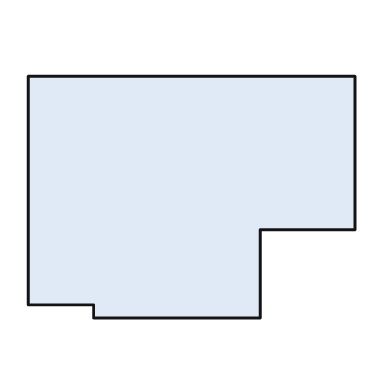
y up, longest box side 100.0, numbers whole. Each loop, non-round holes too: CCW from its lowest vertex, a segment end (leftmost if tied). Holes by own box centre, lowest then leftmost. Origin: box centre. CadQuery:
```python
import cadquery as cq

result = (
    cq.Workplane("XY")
    .moveTo(-30.0, -37.0)
    .lineTo(21.0, -37.0)
    .lineTo(21.0, -10.0)
    .lineTo(50.0, -10.0)
    .lineTo(50.0, 37.0)
    .lineTo(-50.0, 37.0)
    .lineTo(-50.0, -33.0)
    .lineTo(-30.0, -33.0)
    .close()
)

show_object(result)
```